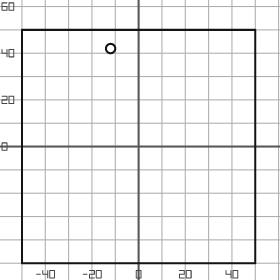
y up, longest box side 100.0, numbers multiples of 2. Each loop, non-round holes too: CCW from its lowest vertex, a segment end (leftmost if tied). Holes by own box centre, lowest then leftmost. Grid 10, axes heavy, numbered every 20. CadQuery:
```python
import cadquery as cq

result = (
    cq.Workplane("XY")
    .moveTo(-50.0, -50.0)
    .lineTo(50.0, -50.0)
    .lineTo(50.0, 50.0)
    .lineTo(-50.0, 50.0)
    .close()
    .moveTo(-12.0, 42.0)
    .circle(2.0)
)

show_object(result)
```